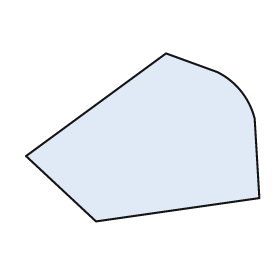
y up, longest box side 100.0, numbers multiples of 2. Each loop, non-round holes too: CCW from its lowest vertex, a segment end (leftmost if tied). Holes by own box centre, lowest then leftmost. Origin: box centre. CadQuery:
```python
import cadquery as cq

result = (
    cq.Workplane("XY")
    .moveTo(-20.0, -36.0)
    .lineTo(50.0, -26.0)
    .lineTo(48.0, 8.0)
    .threePointArc((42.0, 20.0), (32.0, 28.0))
    .lineTo(10.0, 36.0)
    .lineTo(-50.0, -8.0)
    .close()
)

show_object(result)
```